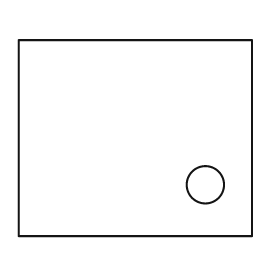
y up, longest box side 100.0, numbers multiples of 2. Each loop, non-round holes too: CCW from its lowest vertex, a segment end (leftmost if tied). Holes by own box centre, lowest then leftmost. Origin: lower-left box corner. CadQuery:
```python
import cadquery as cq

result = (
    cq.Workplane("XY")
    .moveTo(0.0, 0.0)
    .lineTo(100.0, 0.0)
    .lineTo(100.0, 84.0)
    .lineTo(0.0, 84.0)
    .close()
    .moveTo(80.0, 22.0)
    .circle(8.0)
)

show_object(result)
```